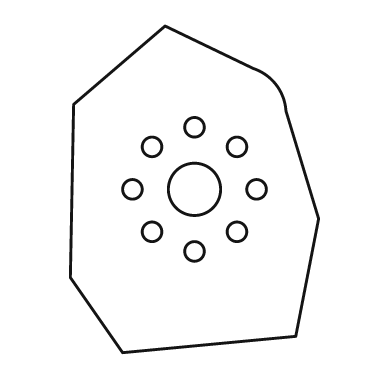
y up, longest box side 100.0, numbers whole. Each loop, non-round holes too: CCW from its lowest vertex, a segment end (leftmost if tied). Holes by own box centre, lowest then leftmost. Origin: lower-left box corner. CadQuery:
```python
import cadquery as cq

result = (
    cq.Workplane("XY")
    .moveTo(16.0, 0.0)
    .lineTo(69.0, 5.0)
    .lineTo(76.0, 41.0)
    .lineTo(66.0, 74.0)
    .threePointArc((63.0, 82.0), (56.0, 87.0))
    .lineTo(29.0, 100.0)
    .lineTo(1.0, 76.0)
    .lineTo(0.0, 23.0)
    .close()
    .moveTo(38.0, 31.0)
    .circle(3.0)
    .moveTo(25.0, 37.0)
    .circle(3.0)
    .moveTo(51.0, 37.0)
    .circle(3.0)
    .moveTo(19.0, 50.0)
    .circle(3.0)
    .moveTo(38.0, 50.0)
    .circle(8.0)
    .moveTo(57.0, 50.0)
    .circle(3.0)
    .moveTo(25.0, 63.0)
    .circle(3.0)
    .moveTo(51.0, 63.0)
    .circle(3.0)
    .moveTo(38.0, 69.0)
    .circle(3.0)
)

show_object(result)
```